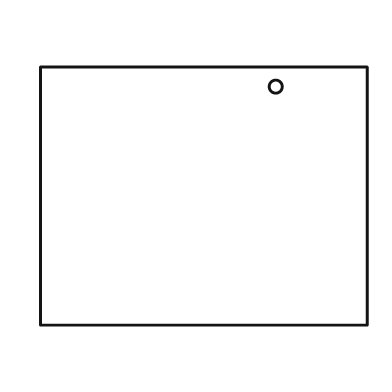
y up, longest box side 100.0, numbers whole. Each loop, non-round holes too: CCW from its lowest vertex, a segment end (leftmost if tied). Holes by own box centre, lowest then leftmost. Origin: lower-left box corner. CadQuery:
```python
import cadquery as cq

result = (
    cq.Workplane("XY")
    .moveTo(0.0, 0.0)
    .lineTo(100.0, 0.0)
    .lineTo(100.0, 79.0)
    .lineTo(0.0, 79.0)
    .close()
    .moveTo(72.0, 73.0)
    .circle(2.0)
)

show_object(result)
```